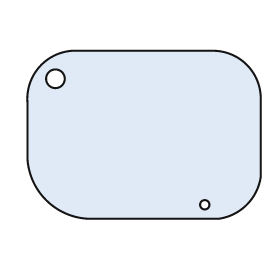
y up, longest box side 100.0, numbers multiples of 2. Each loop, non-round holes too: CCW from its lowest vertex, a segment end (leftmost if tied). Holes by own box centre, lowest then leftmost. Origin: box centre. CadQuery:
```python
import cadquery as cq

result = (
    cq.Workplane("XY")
    .moveTo(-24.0, -36.0)
    .lineTo(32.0, -36.0)
    .threePointArc((44.0, -30.0), (50.0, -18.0))
    .lineTo(50.0, 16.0)
    .threePointArc((44.0, 30.0), (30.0, 36.0))
    .lineTo(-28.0, 36.0)
    .threePointArc((-44.0, 30.0), (-50.0, 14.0))
    .lineTo(-50.0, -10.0)
    .threePointArc((-42.0, -28.0), (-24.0, -36.0))
    .close()
    .moveTo(26.0, -30.0)
    .circle(2.0)
    .moveTo(-38.0, 24.0)
    .circle(4.0)
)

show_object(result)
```